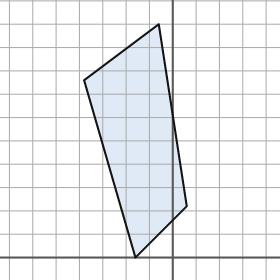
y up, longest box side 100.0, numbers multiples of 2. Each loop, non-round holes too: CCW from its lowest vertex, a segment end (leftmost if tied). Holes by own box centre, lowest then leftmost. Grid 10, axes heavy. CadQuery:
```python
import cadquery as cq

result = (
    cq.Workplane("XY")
    .moveTo(-16.0, 0.0)
    .lineTo(6.0, 22.0)
    .lineTo(-6.0, 100.0)
    .lineTo(-38.0, 76.0)
    .close()
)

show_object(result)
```